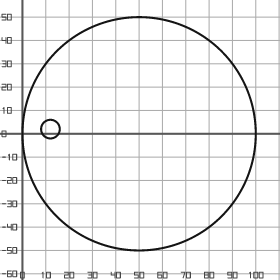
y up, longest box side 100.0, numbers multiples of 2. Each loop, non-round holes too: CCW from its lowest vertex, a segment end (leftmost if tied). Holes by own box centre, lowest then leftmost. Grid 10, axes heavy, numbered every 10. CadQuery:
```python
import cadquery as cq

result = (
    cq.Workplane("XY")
    .moveTo(50.0, 0.0)
    .circle(50.0)
    .moveTo(12.0, 2.0)
    .circle(4.0)
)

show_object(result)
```